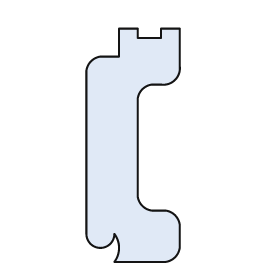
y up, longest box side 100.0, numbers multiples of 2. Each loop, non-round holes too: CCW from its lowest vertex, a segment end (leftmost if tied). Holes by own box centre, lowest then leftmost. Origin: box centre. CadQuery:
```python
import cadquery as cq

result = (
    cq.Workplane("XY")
    .moveTo(-8.0, -50.0)
    .lineTo(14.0, -50.0)
    .threePointArc((18.0, -48.0), (20.0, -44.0))
    .lineTo(20.0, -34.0)
    .threePointArc((18.0, -30.0), (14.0, -28.0))
    .lineTo(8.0, -28.0)
    .threePointArc((4.0, -26.0), (2.0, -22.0))
    .lineTo(2.0, 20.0)
    .threePointArc((4.0, 24.0), (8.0, 26.0))
    .lineTo(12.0, 26.0)
    .threePointArc((18.0, 28.0), (20.0, 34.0))
    .lineTo(20.0, 50.0)
    .lineTo(12.0, 50.0)
    .lineTo(12.0, 46.0)
    .lineTo(2.0, 46.0)
    .lineTo(2.0, 50.0)
    .lineTo(-6.0, 50.0)
    .lineTo(-6.0, 38.0)
    .lineTo(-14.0, 38.0)
    .threePointArc((-18.0, 36.0), (-20.0, 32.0))
    .lineTo(-20.0, -38.0)
    .threePointArc((-14.0, -44.0), (-8.0, -38.0))
    .threePointArc((-6.0, -44.0), (-8.0, -50.0))
    .close()
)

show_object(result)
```